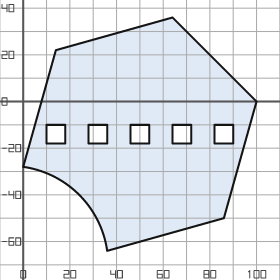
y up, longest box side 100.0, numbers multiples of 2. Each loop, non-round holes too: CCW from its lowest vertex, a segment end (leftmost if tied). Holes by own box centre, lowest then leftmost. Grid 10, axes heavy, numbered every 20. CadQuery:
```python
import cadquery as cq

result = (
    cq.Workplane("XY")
    .moveTo(36.0, -64.0)
    .lineTo(86.0, -50.0)
    .lineTo(100.0, 0.0)
    .lineTo(64.0, 36.0)
    .lineTo(14.0, 22.0)
    .lineTo(0.0, -28.0)
    .threePointArc((24.0, -40.0), (36.0, -64.0))
    .close()
    .moveTo(10.0, -18.0)
    .lineTo(18.0, -18.0)
    .lineTo(18.0, -10.0)
    .lineTo(10.0, -10.0)
    .close()
    .moveTo(28.0, -18.0)
    .lineTo(36.0, -18.0)
    .lineTo(36.0, -10.0)
    .lineTo(28.0, -10.0)
    .close()
    .moveTo(46.0, -18.0)
    .lineTo(54.0, -18.0)
    .lineTo(54.0, -10.0)
    .lineTo(46.0, -10.0)
    .close()
    .moveTo(64.0, -18.0)
    .lineTo(72.0, -18.0)
    .lineTo(72.0, -10.0)
    .lineTo(64.0, -10.0)
    .close()
    .moveTo(82.0, -18.0)
    .lineTo(90.0, -18.0)
    .lineTo(90.0, -10.0)
    .lineTo(82.0, -10.0)
    .close()
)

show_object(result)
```